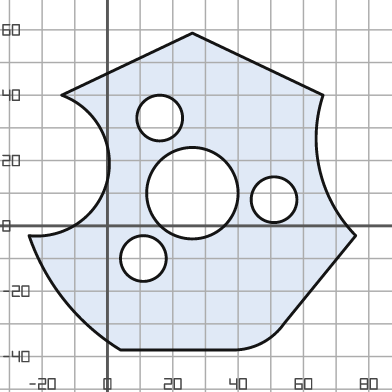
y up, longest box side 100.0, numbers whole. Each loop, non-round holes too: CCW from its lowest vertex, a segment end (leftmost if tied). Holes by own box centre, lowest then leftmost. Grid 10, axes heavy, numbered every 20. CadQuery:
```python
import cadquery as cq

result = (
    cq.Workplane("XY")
    .moveTo(4.0, -38.0)
    .lineTo(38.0, -38.0)
    .threePointArc((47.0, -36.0), (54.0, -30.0))
    .lineTo(76.0, -3.0)
    .threePointArc((65.0, 17.0), (66.0, 40.0))
    .lineTo(26.0, 59.0)
    .lineTo(-14.0, 40.0)
    .threePointArc((0.0, 14.0), (-24.0, -3.0))
    .threePointArc((-13.0, -23.0), (4.0, -38.0))
    .close()
    .moveTo(11.0, -10.0)
    .circle(7.0)
    .moveTo(51.0, 8.0)
    .circle(7.0)
    .moveTo(26.0, 10.0)
    .circle(14.0)
    .moveTo(16.0, 33.0)
    .circle(7.0)
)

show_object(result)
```